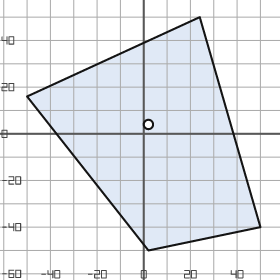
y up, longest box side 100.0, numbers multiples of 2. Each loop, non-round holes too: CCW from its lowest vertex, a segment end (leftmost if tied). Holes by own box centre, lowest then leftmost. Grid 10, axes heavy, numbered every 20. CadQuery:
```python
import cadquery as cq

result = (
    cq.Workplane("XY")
    .moveTo(2.0, -50.0)
    .lineTo(50.0, -40.0)
    .lineTo(24.0, 50.0)
    .lineTo(-50.0, 16.0)
    .close()
    .moveTo(2.0, 4.0)
    .circle(2.0)
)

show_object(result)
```